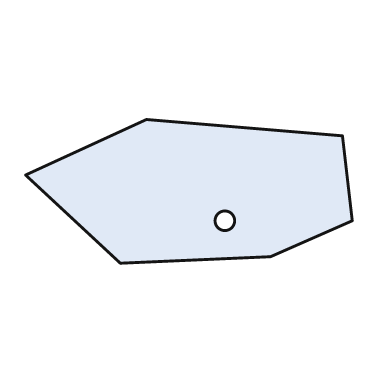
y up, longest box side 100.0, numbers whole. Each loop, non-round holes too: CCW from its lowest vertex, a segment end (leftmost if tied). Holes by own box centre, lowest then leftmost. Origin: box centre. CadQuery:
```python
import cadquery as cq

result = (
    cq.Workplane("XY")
    .moveTo(-21.0, -22.0)
    .lineTo(25.0, -20.0)
    .lineTo(50.0, -9.0)
    .lineTo(47.0, 17.0)
    .lineTo(-13.0, 22.0)
    .lineTo(-50.0, 5.0)
    .close()
    .moveTo(11.0, -9.0)
    .circle(3.0)
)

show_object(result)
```